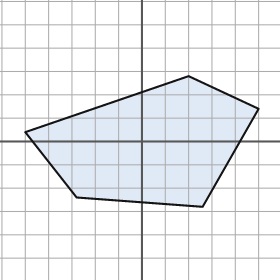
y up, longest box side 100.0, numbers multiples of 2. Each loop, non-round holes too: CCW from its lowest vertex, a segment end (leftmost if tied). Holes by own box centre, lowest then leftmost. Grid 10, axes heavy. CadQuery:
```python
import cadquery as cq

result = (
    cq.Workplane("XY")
    .moveTo(26.0, -28.0)
    .lineTo(50.0, 14.0)
    .lineTo(20.0, 28.0)
    .lineTo(-50.0, 4.0)
    .lineTo(-28.0, -24.0)
    .close()
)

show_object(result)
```